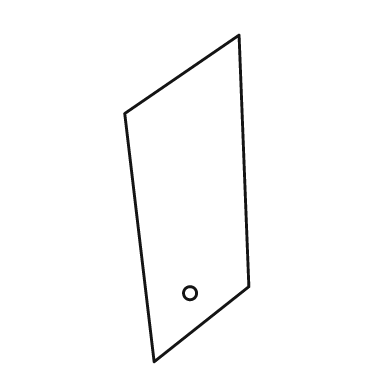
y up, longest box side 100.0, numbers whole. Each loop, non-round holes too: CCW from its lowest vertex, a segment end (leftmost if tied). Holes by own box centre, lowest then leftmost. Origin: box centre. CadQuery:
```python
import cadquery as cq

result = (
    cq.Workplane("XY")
    .moveTo(-10.0, -50.0)
    .lineTo(19.0, -27.0)
    .lineTo(16.0, 50.0)
    .lineTo(-19.0, 26.0)
    .close()
    .moveTo(1.0, -29.0)
    .circle(2.0)
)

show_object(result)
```